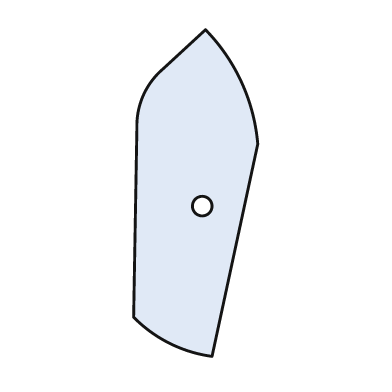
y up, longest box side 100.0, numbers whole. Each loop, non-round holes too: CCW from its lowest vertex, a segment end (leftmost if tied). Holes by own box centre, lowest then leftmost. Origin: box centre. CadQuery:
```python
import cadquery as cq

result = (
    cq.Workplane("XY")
    .moveTo(5.0, -50.0)
    .lineTo(19.0, 15.0)
    .threePointArc((14.0, 34.0), (3.0, 50.0))
    .lineTo(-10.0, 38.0)
    .threePointArc((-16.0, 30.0), (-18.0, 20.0))
    .lineTo(-19.0, -38.0)
    .threePointArc((-8.0, -46.0), (5.0, -50.0))
    .close()
    .moveTo(2.0, -4.0)
    .circle(3.0)
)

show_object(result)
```